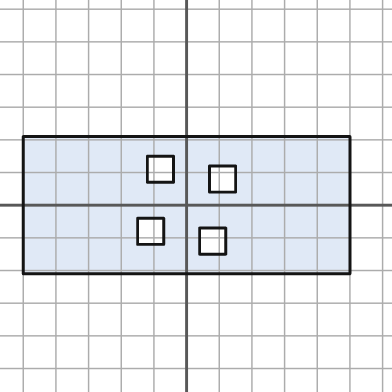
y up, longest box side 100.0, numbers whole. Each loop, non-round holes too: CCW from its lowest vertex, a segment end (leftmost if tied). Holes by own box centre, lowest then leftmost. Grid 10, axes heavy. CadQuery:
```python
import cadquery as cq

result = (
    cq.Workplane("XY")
    .moveTo(-50.0, -21.0)
    .lineTo(50.0, -21.0)
    .lineTo(50.0, 21.0)
    .lineTo(-50.0, 21.0)
    .close()
    .moveTo(4.0, -15.0)
    .lineTo(12.0, -15.0)
    .lineTo(12.0, -7.0)
    .lineTo(4.0, -7.0)
    .close()
    .moveTo(-15.0, -12.0)
    .lineTo(-7.0, -12.0)
    .lineTo(-7.0, -4.0)
    .lineTo(-15.0, -4.0)
    .close()
    .moveTo(7.0, 4.0)
    .lineTo(15.0, 4.0)
    .lineTo(15.0, 12.0)
    .lineTo(7.0, 12.0)
    .close()
    .moveTo(-12.0, 7.0)
    .lineTo(-4.0, 7.0)
    .lineTo(-4.0, 15.0)
    .lineTo(-12.0, 15.0)
    .close()
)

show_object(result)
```